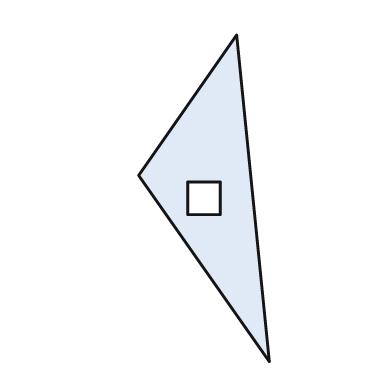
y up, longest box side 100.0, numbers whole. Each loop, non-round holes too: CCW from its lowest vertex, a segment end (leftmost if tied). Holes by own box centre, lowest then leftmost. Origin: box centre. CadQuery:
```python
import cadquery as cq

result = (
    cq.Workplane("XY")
    .moveTo(20.0, -50.0)
    .lineTo(10.0, 50.0)
    .lineTo(-20.0, 7.0)
    .close()
    .moveTo(-5.0, -5.0)
    .lineTo(5.0, -5.0)
    .lineTo(5.0, 5.0)
    .lineTo(-5.0, 5.0)
    .close()
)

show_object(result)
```